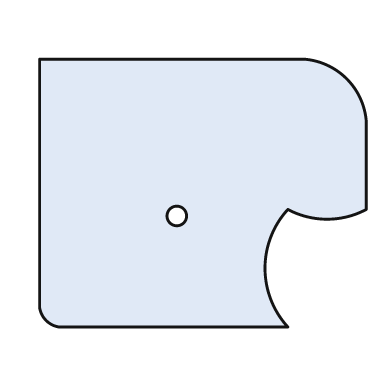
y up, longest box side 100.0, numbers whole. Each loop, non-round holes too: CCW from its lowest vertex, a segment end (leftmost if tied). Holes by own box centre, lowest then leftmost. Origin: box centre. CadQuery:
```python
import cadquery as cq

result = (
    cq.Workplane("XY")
    .moveTo(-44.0, -41.0)
    .lineTo(26.0, -41.0)
    .threePointArc((19.0, -23.0), (26.0, -5.0))
    .threePointArc((38.0, -8.0), (50.0, -5.0))
    .lineTo(50.0, 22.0)
    .threePointArc((44.0, 35.0), (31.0, 41.0))
    .lineTo(-50.0, 41.0)
    .lineTo(-50.0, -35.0)
    .threePointArc((-48.0, -39.0), (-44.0, -41.0))
    .close()
    .moveTo(-8.0, -7.0)
    .circle(3.0)
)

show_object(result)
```